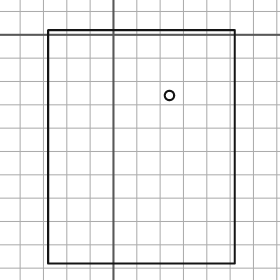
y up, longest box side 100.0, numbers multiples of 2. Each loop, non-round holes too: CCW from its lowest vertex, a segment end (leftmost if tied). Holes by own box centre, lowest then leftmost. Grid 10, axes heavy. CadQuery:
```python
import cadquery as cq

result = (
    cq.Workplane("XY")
    .moveTo(-28.0, -98.0)
    .lineTo(52.0, -98.0)
    .lineTo(52.0, 2.0)
    .lineTo(-28.0, 2.0)
    .close()
    .moveTo(24.0, -26.0)
    .circle(2.0)
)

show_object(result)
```